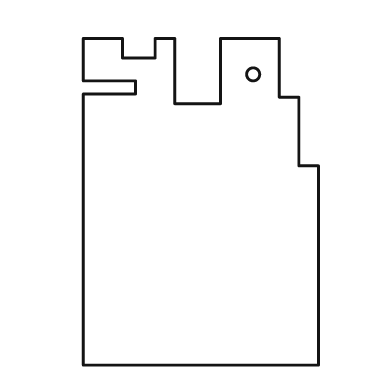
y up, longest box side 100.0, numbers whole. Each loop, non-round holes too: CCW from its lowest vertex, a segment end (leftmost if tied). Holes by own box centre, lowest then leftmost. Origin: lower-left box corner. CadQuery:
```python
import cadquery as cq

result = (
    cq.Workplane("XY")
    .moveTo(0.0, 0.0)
    .lineTo(72.0, 0.0)
    .lineTo(72.0, 61.0)
    .lineTo(66.0, 61.0)
    .lineTo(66.0, 82.0)
    .lineTo(60.0, 82.0)
    .lineTo(60.0, 100.0)
    .lineTo(42.0, 100.0)
    .lineTo(42.0, 80.0)
    .lineTo(28.0, 80.0)
    .lineTo(28.0, 100.0)
    .lineTo(22.0, 100.0)
    .lineTo(22.0, 94.0)
    .lineTo(12.0, 94.0)
    .lineTo(12.0, 100.0)
    .lineTo(0.0, 100.0)
    .lineTo(0.0, 87.0)
    .lineTo(16.0, 87.0)
    .lineTo(16.0, 83.0)
    .lineTo(0.0, 83.0)
    .close()
    .moveTo(52.0, 89.0)
    .circle(2.0)
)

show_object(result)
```